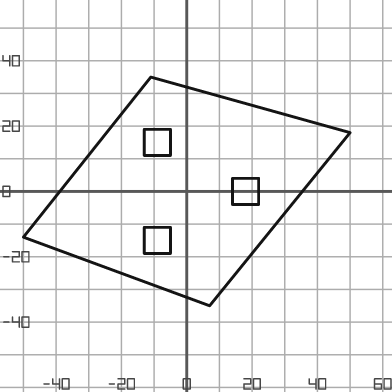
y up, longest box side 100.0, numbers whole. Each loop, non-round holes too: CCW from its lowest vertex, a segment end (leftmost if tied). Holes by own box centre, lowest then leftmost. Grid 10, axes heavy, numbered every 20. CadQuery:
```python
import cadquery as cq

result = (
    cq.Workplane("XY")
    .moveTo(7.0, -35.0)
    .lineTo(50.0, 18.0)
    .lineTo(-11.0, 35.0)
    .lineTo(-50.0, -14.0)
    .close()
    .moveTo(-13.0, -19.0)
    .lineTo(-5.0, -19.0)
    .lineTo(-5.0, -11.0)
    .lineTo(-13.0, -11.0)
    .close()
    .moveTo(14.0, -4.0)
    .lineTo(22.0, -4.0)
    .lineTo(22.0, 4.0)
    .lineTo(14.0, 4.0)
    .close()
    .moveTo(-13.0, 11.0)
    .lineTo(-5.0, 11.0)
    .lineTo(-5.0, 19.0)
    .lineTo(-13.0, 19.0)
    .close()
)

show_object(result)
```